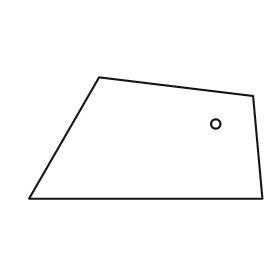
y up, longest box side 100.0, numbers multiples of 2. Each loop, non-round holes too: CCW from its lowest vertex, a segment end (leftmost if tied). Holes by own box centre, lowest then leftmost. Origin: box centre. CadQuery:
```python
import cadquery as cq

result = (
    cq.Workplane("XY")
    .moveTo(-50.0, -26.0)
    .lineTo(50.0, -26.0)
    .lineTo(46.0, 18.0)
    .lineTo(-20.0, 26.0)
    .close()
    .moveTo(30.0, 6.0)
    .circle(2.0)
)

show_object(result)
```